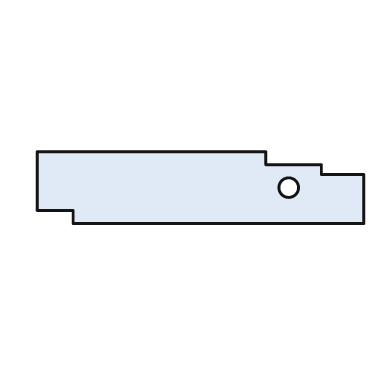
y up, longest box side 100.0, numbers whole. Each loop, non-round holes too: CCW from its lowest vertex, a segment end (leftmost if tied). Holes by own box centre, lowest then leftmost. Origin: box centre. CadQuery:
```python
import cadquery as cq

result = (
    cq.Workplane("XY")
    .moveTo(-39.0, -11.0)
    .lineTo(50.0, -11.0)
    .lineTo(50.0, 4.0)
    .lineTo(37.0, 4.0)
    .lineTo(37.0, 7.0)
    .lineTo(20.0, 7.0)
    .lineTo(20.0, 11.0)
    .lineTo(-50.0, 11.0)
    .lineTo(-50.0, -7.0)
    .lineTo(-39.0, -7.0)
    .close()
    .moveTo(27.0, 0.0)
    .circle(3.0)
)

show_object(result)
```